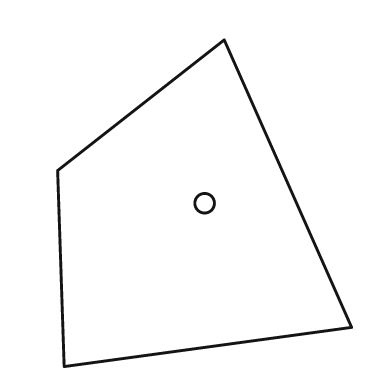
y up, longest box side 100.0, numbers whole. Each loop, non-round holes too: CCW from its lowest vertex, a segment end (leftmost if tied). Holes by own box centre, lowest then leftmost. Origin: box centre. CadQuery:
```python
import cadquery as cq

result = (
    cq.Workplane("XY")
    .moveTo(-43.0, -50.0)
    .lineTo(45.0, -38.0)
    .lineTo(6.0, 50.0)
    .lineTo(-45.0, 10.0)
    .close()
    .moveTo(0.0, 0.0)
    .circle(3.0)
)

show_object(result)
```